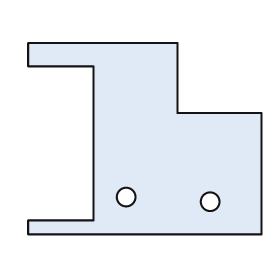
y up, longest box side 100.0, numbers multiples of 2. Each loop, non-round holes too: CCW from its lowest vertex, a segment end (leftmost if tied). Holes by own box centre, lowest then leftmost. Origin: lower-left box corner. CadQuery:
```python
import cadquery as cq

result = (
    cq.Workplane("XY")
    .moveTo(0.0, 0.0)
    .lineTo(100.0, 0.0)
    .lineTo(100.0, 52.0)
    .lineTo(64.0, 52.0)
    .lineTo(64.0, 82.0)
    .lineTo(0.0, 82.0)
    .lineTo(0.0, 72.0)
    .lineTo(28.0, 72.0)
    .lineTo(28.0, 6.0)
    .lineTo(0.0, 6.0)
    .close()
    .moveTo(78.0, 14.0)
    .circle(4.0)
    .moveTo(42.0, 16.0)
    .circle(4.0)
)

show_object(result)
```